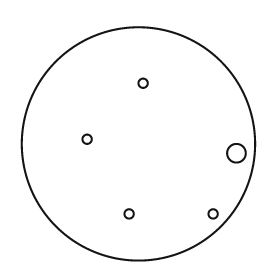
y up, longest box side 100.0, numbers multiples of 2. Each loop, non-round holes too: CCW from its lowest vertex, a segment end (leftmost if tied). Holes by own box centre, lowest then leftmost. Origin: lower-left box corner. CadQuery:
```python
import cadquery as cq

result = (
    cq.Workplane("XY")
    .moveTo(50.0, 50.0)
    .circle(50.0)
    .moveTo(46.0, 20.0)
    .circle(2.0)
    .moveTo(82.0, 20.0)
    .circle(2.0)
    .moveTo(92.0, 46.0)
    .circle(4.0)
    .moveTo(28.0, 52.0)
    .circle(2.0)
    .moveTo(52.0, 76.0)
    .circle(2.0)
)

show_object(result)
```